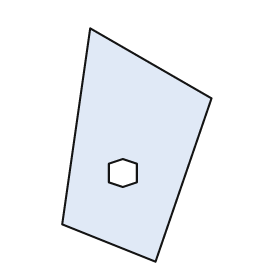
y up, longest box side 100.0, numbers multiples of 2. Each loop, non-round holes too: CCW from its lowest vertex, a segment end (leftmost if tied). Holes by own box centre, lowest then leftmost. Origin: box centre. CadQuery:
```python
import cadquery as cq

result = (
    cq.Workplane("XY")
    .moveTo(8.0, -50.0)
    .lineTo(32.0, 20.0)
    .lineTo(-20.0, 50.0)
    .lineTo(-32.0, -34.0)
    .close()
    .moveTo(-6.0, -18.0)
    .lineTo(0.0, -16.0)
    .lineTo(0.0, -8.0)
    .lineTo(-6.0, -6.0)
    .lineTo(-12.0, -8.0)
    .lineTo(-12.0, -16.0)
    .close()
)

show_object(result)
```